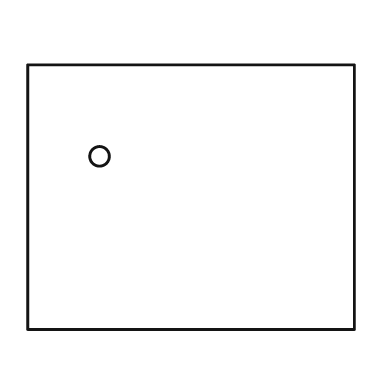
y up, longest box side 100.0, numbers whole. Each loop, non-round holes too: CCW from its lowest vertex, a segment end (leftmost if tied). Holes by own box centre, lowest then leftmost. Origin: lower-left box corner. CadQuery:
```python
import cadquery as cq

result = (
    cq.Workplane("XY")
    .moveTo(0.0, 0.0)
    .lineTo(100.0, 0.0)
    .lineTo(100.0, 81.0)
    .lineTo(0.0, 81.0)
    .close()
    .moveTo(22.0, 53.0)
    .circle(3.0)
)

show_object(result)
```